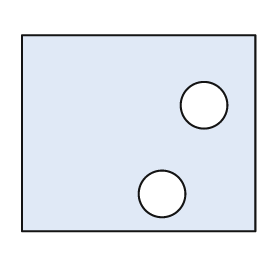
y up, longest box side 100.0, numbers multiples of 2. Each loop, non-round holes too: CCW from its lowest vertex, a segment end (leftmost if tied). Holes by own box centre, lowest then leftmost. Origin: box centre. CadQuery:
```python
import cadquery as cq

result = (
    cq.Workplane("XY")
    .moveTo(-50.0, -42.0)
    .lineTo(50.0, -42.0)
    .lineTo(50.0, 42.0)
    .lineTo(-50.0, 42.0)
    .close()
    .moveTo(10.0, -26.0)
    .circle(10.0)
    .moveTo(28.0, 12.0)
    .circle(10.0)
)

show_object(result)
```